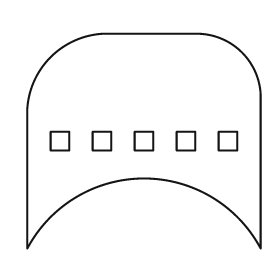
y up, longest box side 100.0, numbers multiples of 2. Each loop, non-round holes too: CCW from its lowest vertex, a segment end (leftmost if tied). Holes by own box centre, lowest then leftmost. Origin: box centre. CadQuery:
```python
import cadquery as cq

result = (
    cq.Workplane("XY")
    .moveTo(-50.0, -46.0)
    .threePointArc((0.0, -16.0), (50.0, -46.0))
    .lineTo(50.0, 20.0)
    .threePointArc((42.0, 38.0), (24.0, 46.0))
    .lineTo(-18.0, 46.0)
    .threePointArc((-40.0, 36.0), (-50.0, 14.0))
    .close()
    .moveTo(-40.0, -4.0)
    .lineTo(-32.0, -4.0)
    .lineTo(-32.0, 4.0)
    .lineTo(-40.0, 4.0)
    .close()
    .moveTo(-22.0, -4.0)
    .lineTo(-14.0, -4.0)
    .lineTo(-14.0, 4.0)
    .lineTo(-22.0, 4.0)
    .close()
    .moveTo(-4.0, -4.0)
    .lineTo(4.0, -4.0)
    .lineTo(4.0, 4.0)
    .lineTo(-4.0, 4.0)
    .close()
    .moveTo(14.0, -4.0)
    .lineTo(22.0, -4.0)
    .lineTo(22.0, 4.0)
    .lineTo(14.0, 4.0)
    .close()
    .moveTo(32.0, -4.0)
    .lineTo(40.0, -4.0)
    .lineTo(40.0, 4.0)
    .lineTo(32.0, 4.0)
    .close()
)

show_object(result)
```